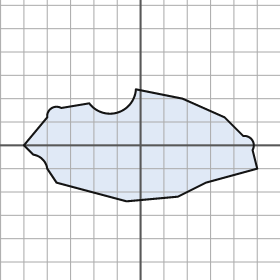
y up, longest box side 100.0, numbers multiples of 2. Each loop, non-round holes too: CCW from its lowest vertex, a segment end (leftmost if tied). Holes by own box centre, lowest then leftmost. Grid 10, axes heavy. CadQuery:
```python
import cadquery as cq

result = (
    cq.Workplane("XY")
    .moveTo(-6.0, -24.0)
    .lineTo(16.0, -22.0)
    .lineTo(28.0, -16.0)
    .lineTo(50.0, -10.0)
    .lineTo(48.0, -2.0)
    .threePointArc((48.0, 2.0), (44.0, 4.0))
    .lineTo(36.0, 12.0)
    .lineTo(18.0, 20.0)
    .lineTo(-2.0, 24.0)
    .threePointArc((-10.0, 14.0), (-22.0, 18.0))
    .lineTo(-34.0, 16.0)
    .threePointArc((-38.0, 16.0), (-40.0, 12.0))
    .lineTo(-50.0, 0.0)
    .lineTo(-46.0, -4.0)
    .threePointArc((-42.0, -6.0), (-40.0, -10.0))
    .lineTo(-36.0, -16.0)
    .close()
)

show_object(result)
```